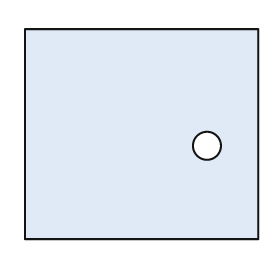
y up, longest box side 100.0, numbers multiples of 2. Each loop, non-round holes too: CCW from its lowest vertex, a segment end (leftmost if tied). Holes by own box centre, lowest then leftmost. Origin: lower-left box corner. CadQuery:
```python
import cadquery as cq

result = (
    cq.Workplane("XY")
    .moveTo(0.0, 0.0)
    .lineTo(100.0, 0.0)
    .lineTo(100.0, 90.0)
    .lineTo(0.0, 90.0)
    .close()
    .moveTo(78.0, 40.0)
    .circle(6.0)
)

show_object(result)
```